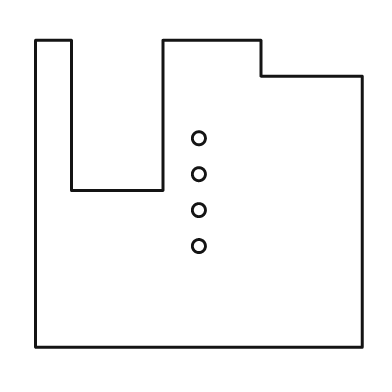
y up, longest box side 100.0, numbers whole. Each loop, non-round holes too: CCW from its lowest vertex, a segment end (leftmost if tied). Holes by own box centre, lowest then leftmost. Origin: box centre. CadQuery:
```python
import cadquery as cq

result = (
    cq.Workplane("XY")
    .moveTo(-50.0, -47.0)
    .lineTo(50.0, -47.0)
    .lineTo(50.0, 36.0)
    .lineTo(19.0, 36.0)
    .lineTo(19.0, 47.0)
    .lineTo(-11.0, 47.0)
    .lineTo(-11.0, 1.0)
    .lineTo(-39.0, 1.0)
    .lineTo(-39.0, 47.0)
    .lineTo(-50.0, 47.0)
    .close()
    .moveTo(0.0, -16.0)
    .circle(2.0)
    .moveTo(0.0, -5.0)
    .circle(2.0)
    .moveTo(0.0, 6.0)
    .circle(2.0)
    .moveTo(0.0, 17.0)
    .circle(2.0)
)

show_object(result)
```